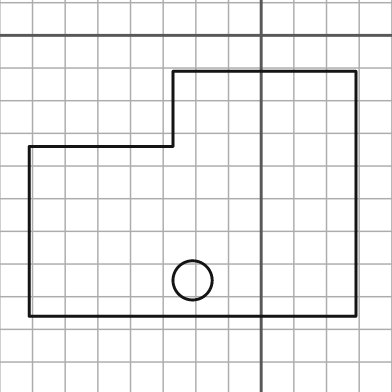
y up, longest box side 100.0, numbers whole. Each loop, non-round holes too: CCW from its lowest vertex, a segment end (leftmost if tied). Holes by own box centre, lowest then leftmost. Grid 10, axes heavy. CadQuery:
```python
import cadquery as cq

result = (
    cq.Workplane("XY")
    .moveTo(-71.0, -86.0)
    .lineTo(29.0, -86.0)
    .lineTo(29.0, -11.0)
    .lineTo(-27.0, -11.0)
    .lineTo(-27.0, -34.0)
    .lineTo(-71.0, -34.0)
    .close()
    .moveTo(-21.0, -75.0)
    .circle(6.0)
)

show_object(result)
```